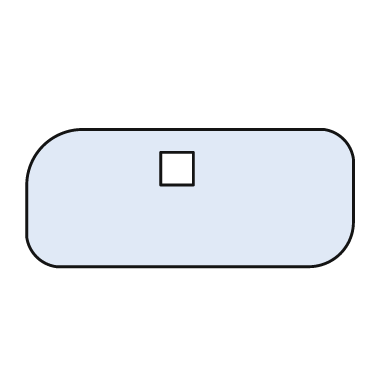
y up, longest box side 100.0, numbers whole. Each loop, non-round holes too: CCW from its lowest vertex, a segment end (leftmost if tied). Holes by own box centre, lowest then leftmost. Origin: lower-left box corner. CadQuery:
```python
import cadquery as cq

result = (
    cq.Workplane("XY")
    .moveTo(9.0, 0.0)
    .lineTo(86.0, 0.0)
    .threePointArc((96.0, 4.0), (100.0, 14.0))
    .lineTo(100.0, 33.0)
    .threePointArc((97.0, 39.0), (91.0, 42.0))
    .lineTo(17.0, 42.0)
    .threePointArc((5.0, 37.0), (0.0, 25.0))
    .lineTo(0.0, 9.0)
    .threePointArc((3.0, 3.0), (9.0, 0.0))
    .close()
    .moveTo(41.0, 25.0)
    .lineTo(51.0, 25.0)
    .lineTo(51.0, 35.0)
    .lineTo(41.0, 35.0)
    .close()
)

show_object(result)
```